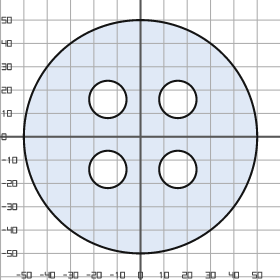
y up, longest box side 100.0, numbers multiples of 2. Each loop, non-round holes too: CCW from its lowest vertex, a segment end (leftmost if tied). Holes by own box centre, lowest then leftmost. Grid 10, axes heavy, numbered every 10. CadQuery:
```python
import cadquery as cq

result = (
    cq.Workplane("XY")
    .moveTo(0.0, 0.0)
    .circle(50.0)
    .moveTo(-14.0, -14.0)
    .circle(8.0)
    .moveTo(16.0, -14.0)
    .circle(8.0)
    .moveTo(-14.0, 16.0)
    .circle(8.0)
    .moveTo(16.0, 16.0)
    .circle(8.0)
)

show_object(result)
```